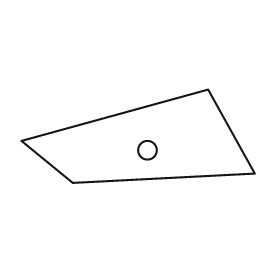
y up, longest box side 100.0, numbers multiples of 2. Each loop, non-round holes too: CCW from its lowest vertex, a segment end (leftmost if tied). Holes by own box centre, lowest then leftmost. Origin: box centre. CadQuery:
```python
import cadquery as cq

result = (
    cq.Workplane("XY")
    .moveTo(-28.0, -20.0)
    .lineTo(50.0, -16.0)
    .lineTo(30.0, 20.0)
    .lineTo(-50.0, -2.0)
    .close()
    .moveTo(4.0, -6.0)
    .circle(4.0)
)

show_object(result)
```